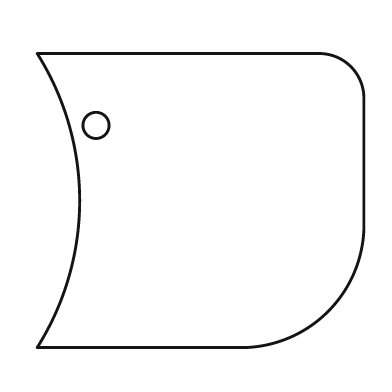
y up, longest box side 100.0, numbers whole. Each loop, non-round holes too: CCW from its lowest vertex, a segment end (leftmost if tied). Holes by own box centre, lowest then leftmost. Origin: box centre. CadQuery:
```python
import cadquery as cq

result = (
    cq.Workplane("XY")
    .moveTo(-50.0, -45.0)
    .lineTo(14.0, -45.0)
    .threePointArc((39.0, -34.0), (50.0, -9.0))
    .lineTo(50.0, 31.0)
    .threePointArc((46.0, 41.0), (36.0, 45.0))
    .lineTo(-50.0, 45.0)
    .threePointArc((-37.0, 0.0), (-50.0, -45.0))
    .close()
    .moveTo(-32.0, 23.0)
    .circle(4.0)
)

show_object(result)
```